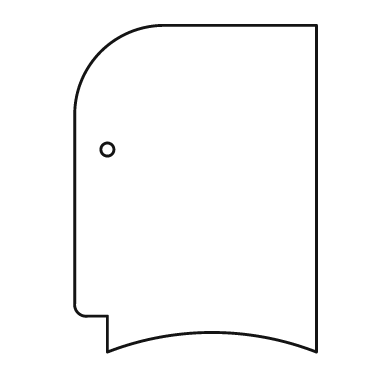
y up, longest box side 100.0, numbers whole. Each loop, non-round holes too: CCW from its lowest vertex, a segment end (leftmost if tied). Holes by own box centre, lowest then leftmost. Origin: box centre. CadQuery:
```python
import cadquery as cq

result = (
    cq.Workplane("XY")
    .moveTo(-27.0, -50.0)
    .threePointArc((5.0, -44.0), (37.0, -50.0))
    .lineTo(37.0, 50.0)
    .lineTo(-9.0, 50.0)
    .threePointArc((-29.0, 42.0), (-37.0, 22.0))
    .lineTo(-37.0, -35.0)
    .threePointArc((-36.0, -38.0), (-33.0, -39.0))
    .lineTo(-27.0, -39.0)
    .close()
    .moveTo(-27.0, 12.0)
    .circle(2.0)
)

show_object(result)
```